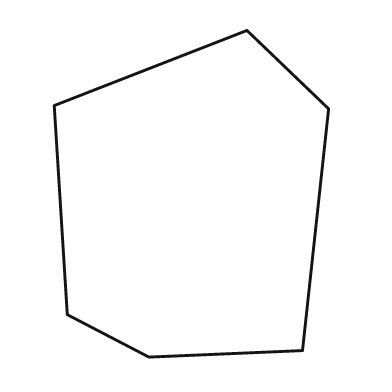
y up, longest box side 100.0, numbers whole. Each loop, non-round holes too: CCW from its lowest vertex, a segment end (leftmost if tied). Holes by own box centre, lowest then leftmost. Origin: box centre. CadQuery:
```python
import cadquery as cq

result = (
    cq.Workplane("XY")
    .moveTo(-13.0, -50.0)
    .lineTo(34.0, -48.0)
    .lineTo(42.0, 26.0)
    .lineTo(17.0, 50.0)
    .lineTo(-42.0, 27.0)
    .lineTo(-38.0, -37.0)
    .close()
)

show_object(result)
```